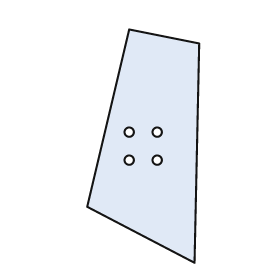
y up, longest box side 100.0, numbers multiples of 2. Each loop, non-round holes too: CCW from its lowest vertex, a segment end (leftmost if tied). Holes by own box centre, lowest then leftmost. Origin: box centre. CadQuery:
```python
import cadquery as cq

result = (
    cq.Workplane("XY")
    .moveTo(22.0, -50.0)
    .lineTo(24.0, 44.0)
    .lineTo(-6.0, 50.0)
    .lineTo(-24.0, -26.0)
    .close()
    .moveTo(-6.0, -6.0)
    .circle(2.0)
    .moveTo(6.0, -6.0)
    .circle(2.0)
    .moveTo(-6.0, 6.0)
    .circle(2.0)
    .moveTo(6.0, 6.0)
    .circle(2.0)
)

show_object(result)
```